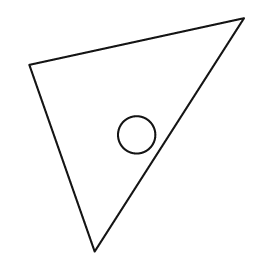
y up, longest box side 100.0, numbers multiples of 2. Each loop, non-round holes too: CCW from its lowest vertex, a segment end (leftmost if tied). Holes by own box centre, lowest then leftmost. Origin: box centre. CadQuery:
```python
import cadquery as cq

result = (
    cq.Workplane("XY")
    .moveTo(-18.0, -50.0)
    .lineTo(46.0, 50.0)
    .lineTo(-46.0, 30.0)
    .close()
    .moveTo(0.0, 0.0)
    .circle(8.0)
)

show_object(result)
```